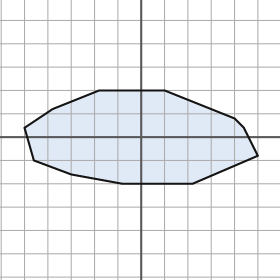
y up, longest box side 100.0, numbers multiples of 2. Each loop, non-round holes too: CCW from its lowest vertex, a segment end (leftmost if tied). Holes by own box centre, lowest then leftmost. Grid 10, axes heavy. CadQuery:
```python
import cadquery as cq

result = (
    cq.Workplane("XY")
    .moveTo(-8.0, -20.0)
    .lineTo(22.0, -20.0)
    .lineTo(50.0, -8.0)
    .lineTo(44.0, 4.0)
    .lineTo(40.0, 8.0)
    .lineTo(10.0, 20.0)
    .lineTo(-18.0, 20.0)
    .lineTo(-38.0, 12.0)
    .lineTo(-50.0, 4.0)
    .lineTo(-46.0, -10.0)
    .lineTo(-30.0, -16.0)
    .close()
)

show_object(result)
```